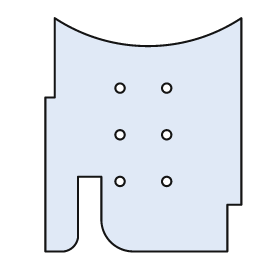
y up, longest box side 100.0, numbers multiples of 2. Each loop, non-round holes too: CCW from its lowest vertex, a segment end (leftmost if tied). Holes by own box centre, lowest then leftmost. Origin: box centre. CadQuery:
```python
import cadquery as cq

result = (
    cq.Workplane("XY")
    .moveTo(-42.0, -50.0)
    .lineTo(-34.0, -50.0)
    .threePointArc((-30.0, -48.0), (-28.0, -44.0))
    .lineTo(-28.0, -18.0)
    .lineTo(-18.0, -18.0)
    .lineTo(-18.0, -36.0)
    .threePointArc((-14.0, -46.0), (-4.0, -50.0))
    .lineTo(36.0, -50.0)
    .lineTo(36.0, -30.0)
    .lineTo(42.0, -30.0)
    .lineTo(42.0, 50.0)
    .threePointArc((2.0, 38.0), (-38.0, 50.0))
    .lineTo(-38.0, 16.0)
    .lineTo(-42.0, 16.0)
    .close()
    .moveTo(-10.0, -20.0)
    .circle(2.0)
    .moveTo(10.0, -20.0)
    .circle(2.0)
    .moveTo(-10.0, 0.0)
    .circle(2.0)
    .moveTo(10.0, 0.0)
    .circle(2.0)
    .moveTo(-10.0, 20.0)
    .circle(2.0)
    .moveTo(10.0, 20.0)
    .circle(2.0)
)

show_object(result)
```